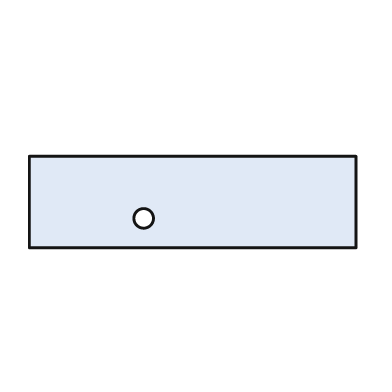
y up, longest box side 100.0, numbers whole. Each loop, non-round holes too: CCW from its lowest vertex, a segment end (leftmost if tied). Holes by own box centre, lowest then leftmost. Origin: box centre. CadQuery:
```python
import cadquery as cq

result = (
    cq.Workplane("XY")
    .moveTo(-50.0, -14.0)
    .lineTo(50.0, -14.0)
    .lineTo(50.0, 14.0)
    .lineTo(-50.0, 14.0)
    .close()
    .moveTo(-15.0, -5.0)
    .circle(3.0)
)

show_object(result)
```